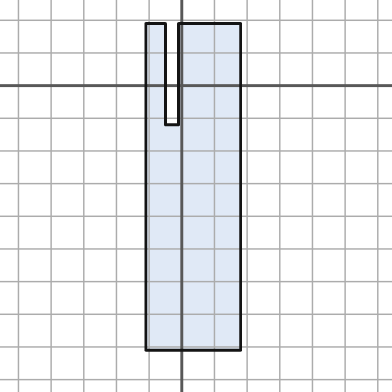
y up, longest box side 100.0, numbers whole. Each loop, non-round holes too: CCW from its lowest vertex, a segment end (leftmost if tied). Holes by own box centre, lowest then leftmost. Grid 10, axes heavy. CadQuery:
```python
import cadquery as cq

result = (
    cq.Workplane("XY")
    .moveTo(-11.0, -81.0)
    .lineTo(18.0, -81.0)
    .lineTo(18.0, 19.0)
    .lineTo(-1.0, 19.0)
    .lineTo(-1.0, -12.0)
    .lineTo(-5.0, -12.0)
    .lineTo(-5.0, 19.0)
    .lineTo(-11.0, 19.0)
    .close()
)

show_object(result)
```